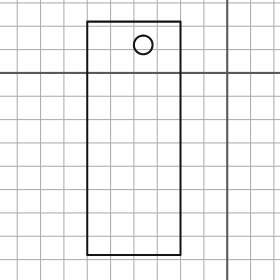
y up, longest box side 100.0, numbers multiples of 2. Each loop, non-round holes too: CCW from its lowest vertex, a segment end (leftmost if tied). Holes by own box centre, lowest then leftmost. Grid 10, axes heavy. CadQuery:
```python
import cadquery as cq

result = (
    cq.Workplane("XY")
    .moveTo(-60.0, -78.0)
    .lineTo(-20.0, -78.0)
    .lineTo(-20.0, 22.0)
    .lineTo(-60.0, 22.0)
    .close()
    .moveTo(-36.0, 12.0)
    .circle(4.0)
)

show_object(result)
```